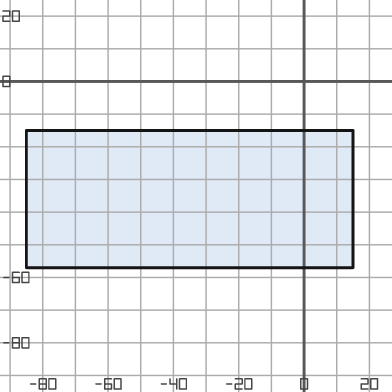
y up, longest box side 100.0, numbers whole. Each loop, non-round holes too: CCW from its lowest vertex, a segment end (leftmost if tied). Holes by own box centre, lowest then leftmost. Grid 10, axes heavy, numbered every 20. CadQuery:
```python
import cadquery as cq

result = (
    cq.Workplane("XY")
    .moveTo(-85.0, -57.0)
    .lineTo(15.0, -57.0)
    .lineTo(15.0, -15.0)
    .lineTo(-85.0, -15.0)
    .close()
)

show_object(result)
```